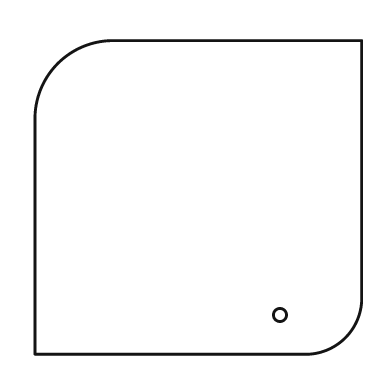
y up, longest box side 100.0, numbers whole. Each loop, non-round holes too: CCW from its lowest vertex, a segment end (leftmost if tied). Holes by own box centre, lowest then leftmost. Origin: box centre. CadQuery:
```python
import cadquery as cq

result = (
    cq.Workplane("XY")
    .moveTo(-50.0, -48.0)
    .lineTo(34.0, -48.0)
    .threePointArc((45.0, -43.0), (50.0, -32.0))
    .lineTo(50.0, 48.0)
    .lineTo(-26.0, 48.0)
    .threePointArc((-43.0, 41.0), (-50.0, 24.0))
    .close()
    .moveTo(25.0, -36.0)
    .circle(2.0)
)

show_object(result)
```